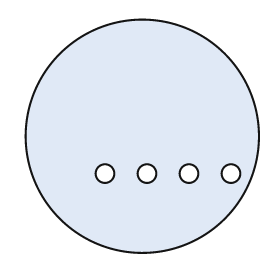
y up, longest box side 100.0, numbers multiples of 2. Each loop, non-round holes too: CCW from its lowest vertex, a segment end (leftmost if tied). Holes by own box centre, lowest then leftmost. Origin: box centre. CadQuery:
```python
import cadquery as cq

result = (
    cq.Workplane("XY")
    .moveTo(0.0, 0.0)
    .circle(50.0)
    .moveTo(-16.0, -16.0)
    .circle(4.0)
    .moveTo(2.0, -16.0)
    .circle(4.0)
    .moveTo(20.0, -16.0)
    .circle(4.0)
    .moveTo(38.0, -16.0)
    .circle(4.0)
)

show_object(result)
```